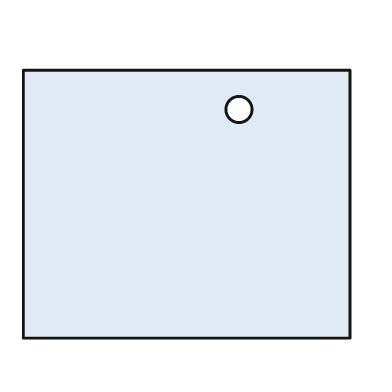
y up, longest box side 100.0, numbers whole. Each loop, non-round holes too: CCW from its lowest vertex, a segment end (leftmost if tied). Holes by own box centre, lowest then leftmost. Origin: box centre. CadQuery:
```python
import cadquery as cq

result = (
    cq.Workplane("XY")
    .moveTo(-50.0, -41.0)
    .lineTo(50.0, -41.0)
    .lineTo(50.0, 41.0)
    .lineTo(-50.0, 41.0)
    .close()
    .moveTo(16.0, 29.0)
    .circle(4.0)
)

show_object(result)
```